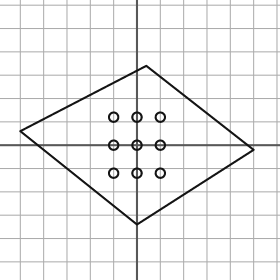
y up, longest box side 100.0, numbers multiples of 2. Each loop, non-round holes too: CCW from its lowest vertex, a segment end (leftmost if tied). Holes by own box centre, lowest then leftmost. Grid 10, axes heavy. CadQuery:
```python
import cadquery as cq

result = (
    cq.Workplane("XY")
    .moveTo(0.0, -34.0)
    .lineTo(50.0, -2.0)
    .lineTo(4.0, 34.0)
    .lineTo(-50.0, 6.0)
    .close()
    .moveTo(-10.0, -12.0)
    .circle(2.0)
    .moveTo(0.0, -12.0)
    .circle(2.0)
    .moveTo(10.0, -12.0)
    .circle(2.0)
    .moveTo(-10.0, 0.0)
    .circle(2.0)
    .moveTo(0.0, 0.0)
    .circle(2.0)
    .moveTo(10.0, 0.0)
    .circle(2.0)
    .moveTo(-10.0, 12.0)
    .circle(2.0)
    .moveTo(0.0, 12.0)
    .circle(2.0)
    .moveTo(10.0, 12.0)
    .circle(2.0)
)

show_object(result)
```